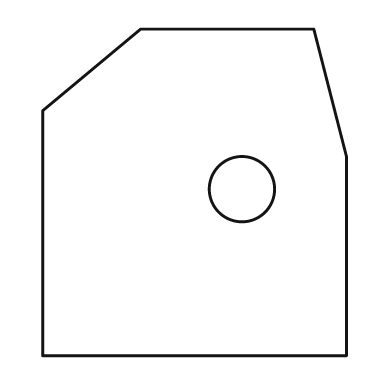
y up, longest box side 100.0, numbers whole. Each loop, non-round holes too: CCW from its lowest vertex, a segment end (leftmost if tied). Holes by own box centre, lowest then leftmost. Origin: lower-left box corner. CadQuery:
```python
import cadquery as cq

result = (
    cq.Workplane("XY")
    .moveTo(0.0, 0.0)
    .lineTo(93.0, 0.0)
    .lineTo(93.0, 61.0)
    .lineTo(83.0, 100.0)
    .lineTo(30.0, 100.0)
    .lineTo(0.0, 75.0)
    .close()
    .moveTo(61.0, 51.0)
    .circle(10.0)
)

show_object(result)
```